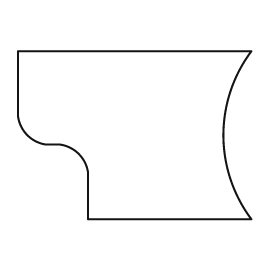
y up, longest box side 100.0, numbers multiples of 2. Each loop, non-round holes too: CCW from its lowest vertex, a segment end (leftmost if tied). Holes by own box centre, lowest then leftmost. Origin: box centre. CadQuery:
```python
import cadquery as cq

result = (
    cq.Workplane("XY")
    .moveTo(-20.0, -36.0)
    .lineTo(50.0, -36.0)
    .threePointArc((38.0, 0.0), (50.0, 36.0))
    .lineTo(-50.0, 36.0)
    .lineTo(-50.0, 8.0)
    .threePointArc((-46.0, 0.0), (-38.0, -4.0))
    .lineTo(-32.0, -4.0)
    .threePointArc((-24.0, -8.0), (-20.0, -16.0))
    .close()
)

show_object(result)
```